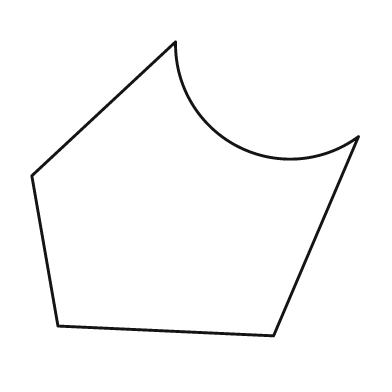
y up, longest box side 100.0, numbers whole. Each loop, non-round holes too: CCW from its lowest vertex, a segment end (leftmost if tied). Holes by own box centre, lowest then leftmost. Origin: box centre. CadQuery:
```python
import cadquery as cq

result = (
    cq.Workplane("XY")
    .moveTo(24.0, -45.0)
    .lineTo(50.0, 16.0)
    .threePointArc((13.0, 13.0), (-6.0, 45.0))
    .lineTo(-50.0, 4.0)
    .lineTo(-42.0, -42.0)
    .close()
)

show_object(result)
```